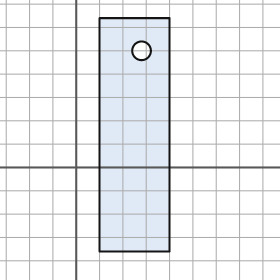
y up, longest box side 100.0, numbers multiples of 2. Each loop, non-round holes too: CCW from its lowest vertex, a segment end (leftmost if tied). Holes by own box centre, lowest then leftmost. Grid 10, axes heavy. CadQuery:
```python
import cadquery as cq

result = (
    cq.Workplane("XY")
    .moveTo(10.0, -36.0)
    .lineTo(40.0, -36.0)
    .lineTo(40.0, 64.0)
    .lineTo(10.0, 64.0)
    .close()
    .moveTo(28.0, 50.0)
    .circle(4.0)
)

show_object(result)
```